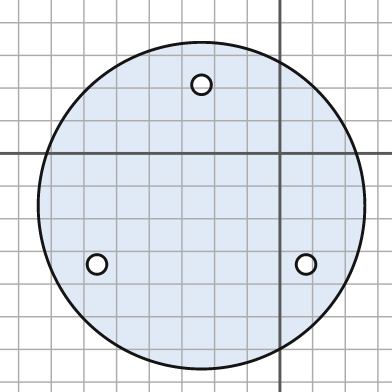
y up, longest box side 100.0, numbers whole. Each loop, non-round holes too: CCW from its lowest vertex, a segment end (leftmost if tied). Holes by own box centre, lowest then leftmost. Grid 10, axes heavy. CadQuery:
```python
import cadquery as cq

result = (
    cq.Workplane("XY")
    .moveTo(-24.0, -16.0)
    .circle(50.0)
    .moveTo(-56.0, -34.0)
    .circle(3.0)
    .moveTo(8.0, -34.0)
    .circle(3.0)
    .moveTo(-24.0, 21.0)
    .circle(3.0)
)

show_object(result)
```